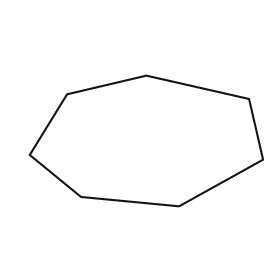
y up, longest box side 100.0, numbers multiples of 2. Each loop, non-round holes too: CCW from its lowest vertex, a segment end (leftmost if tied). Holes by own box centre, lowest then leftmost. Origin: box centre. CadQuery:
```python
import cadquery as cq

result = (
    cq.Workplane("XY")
    .moveTo(14.0, -28.0)
    .lineTo(50.0, -8.0)
    .lineTo(44.0, 18.0)
    .lineTo(0.0, 28.0)
    .lineTo(-34.0, 20.0)
    .lineTo(-50.0, -6.0)
    .lineTo(-28.0, -24.0)
    .close()
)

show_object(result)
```